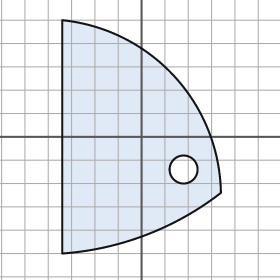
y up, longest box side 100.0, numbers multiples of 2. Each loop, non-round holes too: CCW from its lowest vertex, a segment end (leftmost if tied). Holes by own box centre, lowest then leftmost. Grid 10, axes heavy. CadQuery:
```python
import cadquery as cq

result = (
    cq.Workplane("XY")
    .moveTo(-34.0, -50.0)
    .threePointArc((2.0, -42.0), (34.0, -24.0))
    .threePointArc((14.0, 26.0), (-34.0, 50.0))
    .close()
    .moveTo(18.0, -14.0)
    .circle(6.0)
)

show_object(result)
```